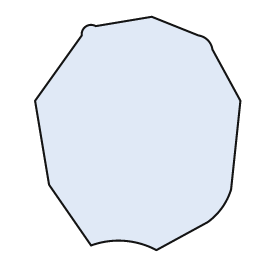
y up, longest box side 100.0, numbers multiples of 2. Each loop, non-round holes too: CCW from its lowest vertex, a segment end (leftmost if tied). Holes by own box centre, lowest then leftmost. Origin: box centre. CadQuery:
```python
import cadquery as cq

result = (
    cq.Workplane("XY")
    .moveTo(8.0, -50.0)
    .lineTo(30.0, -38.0)
    .threePointArc((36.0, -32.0), (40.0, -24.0))
    .lineTo(44.0, 14.0)
    .lineTo(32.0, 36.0)
    .threePointArc((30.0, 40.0), (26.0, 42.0))
    .lineTo(6.0, 50.0)
    .lineTo(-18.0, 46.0)
    .threePointArc((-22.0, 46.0), (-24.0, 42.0))
    .lineTo(-44.0, 14.0)
    .lineTo(-38.0, -22.0)
    .lineTo(-20.0, -48.0)
    .threePointArc((-6.0, -46.0), (8.0, -50.0))
    .close()
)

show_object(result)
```